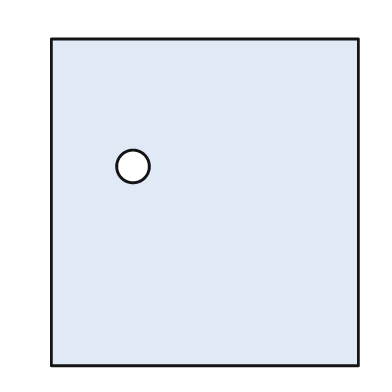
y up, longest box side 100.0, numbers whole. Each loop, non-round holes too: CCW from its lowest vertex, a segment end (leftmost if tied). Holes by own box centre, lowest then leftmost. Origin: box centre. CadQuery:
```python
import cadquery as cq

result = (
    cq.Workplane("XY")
    .moveTo(-47.0, -50.0)
    .lineTo(47.0, -50.0)
    .lineTo(47.0, 50.0)
    .lineTo(-47.0, 50.0)
    .close()
    .moveTo(-22.0, 11.0)
    .circle(5.0)
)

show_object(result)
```